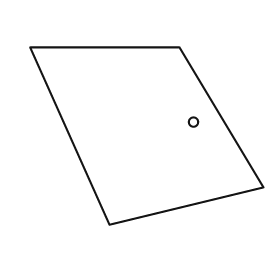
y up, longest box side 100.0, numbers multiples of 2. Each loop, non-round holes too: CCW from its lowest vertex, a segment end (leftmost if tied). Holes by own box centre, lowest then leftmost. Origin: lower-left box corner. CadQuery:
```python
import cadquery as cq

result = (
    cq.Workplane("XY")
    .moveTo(34.0, 0.0)
    .lineTo(100.0, 16.0)
    .lineTo(64.0, 76.0)
    .lineTo(0.0, 76.0)
    .close()
    .moveTo(70.0, 44.0)
    .circle(2.0)
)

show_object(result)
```